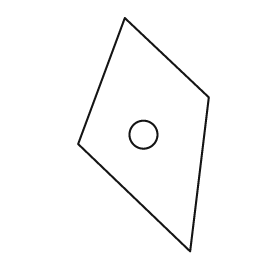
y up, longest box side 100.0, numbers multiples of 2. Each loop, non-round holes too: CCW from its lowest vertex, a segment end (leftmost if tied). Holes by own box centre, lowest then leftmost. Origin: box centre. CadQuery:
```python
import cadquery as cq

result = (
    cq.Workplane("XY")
    .moveTo(20.0, -50.0)
    .lineTo(28.0, 16.0)
    .lineTo(-8.0, 50.0)
    .lineTo(-28.0, -4.0)
    .close()
    .moveTo(0.0, 0.0)
    .circle(6.0)
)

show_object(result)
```